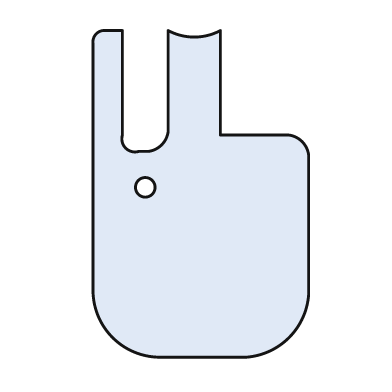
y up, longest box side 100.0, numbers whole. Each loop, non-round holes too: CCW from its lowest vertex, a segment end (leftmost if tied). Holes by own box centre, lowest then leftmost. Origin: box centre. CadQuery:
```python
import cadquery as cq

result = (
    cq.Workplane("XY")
    .moveTo(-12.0, -50.0)
    .lineTo(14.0, -50.0)
    .threePointArc((27.0, -44.0), (33.0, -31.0))
    .lineTo(33.0, 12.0)
    .threePointArc((31.0, 16.0), (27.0, 18.0))
    .lineTo(6.0, 18.0)
    .lineTo(6.0, 50.0)
    .threePointArc((-2.0, 48.0), (-10.0, 50.0))
    .lineTo(-10.0, 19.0)
    .threePointArc((-12.0, 15.0), (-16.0, 13.0))
    .lineTo(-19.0, 13.0)
    .threePointArc((-23.0, 14.0), (-24.0, 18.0))
    .lineTo(-24.0, 50.0)
    .lineTo(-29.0, 50.0)
    .threePointArc((-32.0, 49.0), (-33.0, 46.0))
    .lineTo(-33.0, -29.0)
    .threePointArc((-27.0, -44.0), (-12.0, -50.0))
    .close()
    .moveTo(-17.0, 2.0)
    .circle(3.0)
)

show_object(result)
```